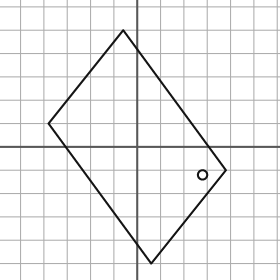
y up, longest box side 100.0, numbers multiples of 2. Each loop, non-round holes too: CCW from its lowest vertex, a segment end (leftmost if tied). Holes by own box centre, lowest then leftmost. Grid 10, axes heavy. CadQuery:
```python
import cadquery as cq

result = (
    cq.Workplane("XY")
    .moveTo(6.0, -50.0)
    .lineTo(38.0, -10.0)
    .lineTo(-6.0, 50.0)
    .lineTo(-38.0, 10.0)
    .close()
    .moveTo(28.0, -12.0)
    .circle(2.0)
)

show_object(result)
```